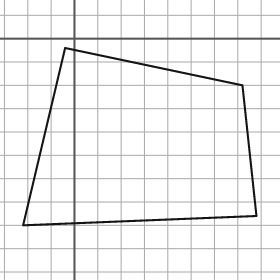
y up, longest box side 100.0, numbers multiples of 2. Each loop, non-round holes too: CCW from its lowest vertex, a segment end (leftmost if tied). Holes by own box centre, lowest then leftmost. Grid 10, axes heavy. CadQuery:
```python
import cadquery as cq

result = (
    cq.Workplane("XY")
    .moveTo(-22.0, -80.0)
    .lineTo(78.0, -76.0)
    .lineTo(72.0, -20.0)
    .lineTo(-4.0, -4.0)
    .close()
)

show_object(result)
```